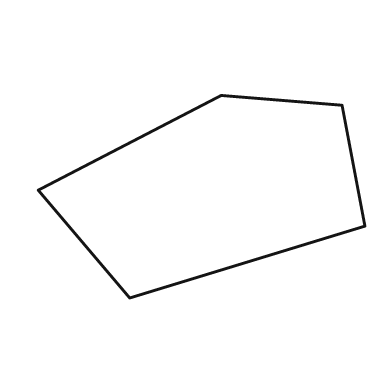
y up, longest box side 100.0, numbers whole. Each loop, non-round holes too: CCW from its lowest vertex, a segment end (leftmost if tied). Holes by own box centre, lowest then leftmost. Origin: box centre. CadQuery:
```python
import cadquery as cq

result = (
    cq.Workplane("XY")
    .moveTo(-22.0, -31.0)
    .lineTo(50.0, -9.0)
    .lineTo(43.0, 28.0)
    .lineTo(6.0, 31.0)
    .lineTo(-50.0, 2.0)
    .close()
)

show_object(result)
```